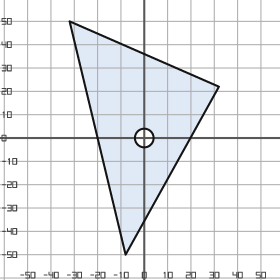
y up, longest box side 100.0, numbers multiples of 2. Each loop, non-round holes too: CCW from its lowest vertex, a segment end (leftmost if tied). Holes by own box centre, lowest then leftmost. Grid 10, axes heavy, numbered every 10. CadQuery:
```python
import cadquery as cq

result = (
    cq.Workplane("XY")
    .moveTo(-8.0, -50.0)
    .lineTo(32.0, 22.0)
    .lineTo(-32.0, 50.0)
    .close()
    .moveTo(0.0, 0.0)
    .circle(4.0)
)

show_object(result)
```